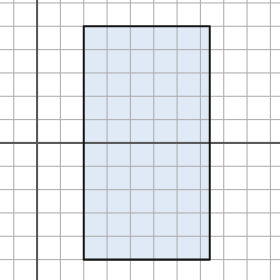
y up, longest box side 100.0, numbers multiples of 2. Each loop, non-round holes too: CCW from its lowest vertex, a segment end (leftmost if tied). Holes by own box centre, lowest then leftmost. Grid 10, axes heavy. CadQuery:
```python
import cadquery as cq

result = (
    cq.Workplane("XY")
    .moveTo(20.0, -50.0)
    .lineTo(74.0, -50.0)
    .lineTo(74.0, 50.0)
    .lineTo(20.0, 50.0)
    .close()
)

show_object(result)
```